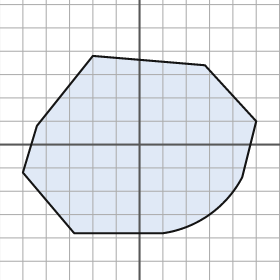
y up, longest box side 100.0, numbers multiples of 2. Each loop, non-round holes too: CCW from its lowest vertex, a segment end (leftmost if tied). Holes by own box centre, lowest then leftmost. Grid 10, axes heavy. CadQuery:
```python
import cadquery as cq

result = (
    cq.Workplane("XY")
    .moveTo(-28.0, -38.0)
    .lineTo(10.0, -38.0)
    .threePointArc((30.0, -30.0), (44.0, -14.0))
    .lineTo(50.0, 10.0)
    .lineTo(28.0, 34.0)
    .lineTo(-20.0, 38.0)
    .lineTo(-44.0, 8.0)
    .lineTo(-50.0, -12.0)
    .close()
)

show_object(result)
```